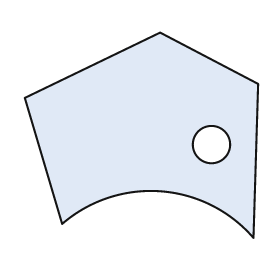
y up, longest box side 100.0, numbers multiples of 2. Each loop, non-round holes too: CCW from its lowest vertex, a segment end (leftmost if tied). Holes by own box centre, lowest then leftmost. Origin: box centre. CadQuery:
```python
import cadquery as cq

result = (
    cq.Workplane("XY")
    .moveTo(48.0, -44.0)
    .lineTo(50.0, 22.0)
    .lineTo(8.0, 44.0)
    .lineTo(-50.0, 16.0)
    .lineTo(-34.0, -38.0)
    .threePointArc((8.0, -24.0), (48.0, -44.0))
    .close()
    .moveTo(30.0, -4.0)
    .circle(8.0)
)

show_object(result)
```